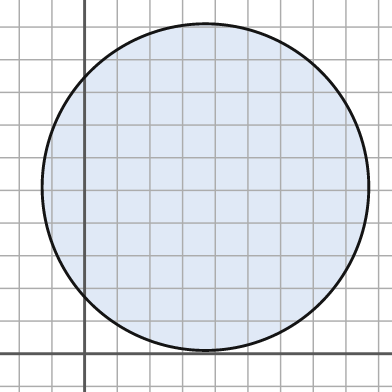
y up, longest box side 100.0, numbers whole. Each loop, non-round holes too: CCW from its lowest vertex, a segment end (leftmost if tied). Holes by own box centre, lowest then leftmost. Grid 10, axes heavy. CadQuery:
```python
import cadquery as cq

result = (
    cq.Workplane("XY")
    .moveTo(37.0, 51.0)
    .circle(50.0)
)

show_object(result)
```